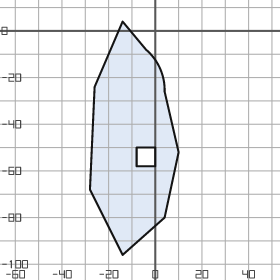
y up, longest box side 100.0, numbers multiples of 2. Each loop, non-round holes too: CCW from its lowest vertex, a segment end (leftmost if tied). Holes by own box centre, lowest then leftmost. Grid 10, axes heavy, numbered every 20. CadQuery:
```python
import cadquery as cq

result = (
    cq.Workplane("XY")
    .moveTo(-14.0, -96.0)
    .lineTo(4.0, -80.0)
    .lineTo(10.0, -52.0)
    .lineTo(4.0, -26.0)
    .threePointArc((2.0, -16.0), (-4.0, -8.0))
    .lineTo(-14.0, 4.0)
    .lineTo(-26.0, -24.0)
    .lineTo(-28.0, -68.0)
    .close()
    .moveTo(-8.0, -58.0)
    .lineTo(0.0, -58.0)
    .lineTo(0.0, -50.0)
    .lineTo(-8.0, -50.0)
    .close()
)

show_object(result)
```